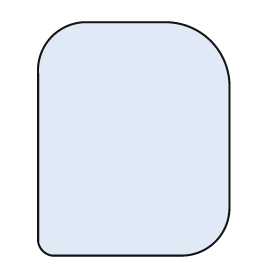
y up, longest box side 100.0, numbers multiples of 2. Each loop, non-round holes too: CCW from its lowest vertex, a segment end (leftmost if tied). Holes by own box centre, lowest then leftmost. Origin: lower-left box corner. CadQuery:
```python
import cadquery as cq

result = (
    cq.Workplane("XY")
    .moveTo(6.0, 0.0)
    .lineTo(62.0, 0.0)
    .threePointArc((76.0, 6.0), (82.0, 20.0))
    .lineTo(82.0, 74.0)
    .threePointArc((74.0, 92.0), (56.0, 100.0))
    .lineTo(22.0, 100.0)
    .threePointArc((6.0, 94.0), (0.0, 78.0))
    .lineTo(0.0, 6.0)
    .threePointArc((2.0, 2.0), (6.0, 0.0))
    .close()
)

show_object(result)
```